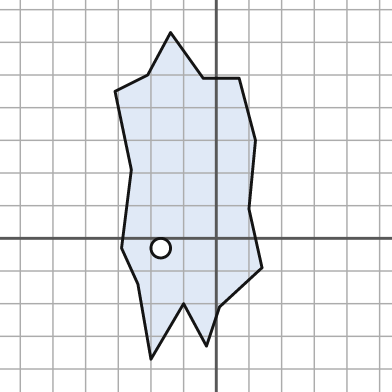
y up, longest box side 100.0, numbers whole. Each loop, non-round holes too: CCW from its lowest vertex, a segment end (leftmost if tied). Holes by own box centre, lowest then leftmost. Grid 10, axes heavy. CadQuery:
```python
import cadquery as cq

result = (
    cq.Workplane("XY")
    .moveTo(-20.0, -37.0)
    .lineTo(-10.0, -20.0)
    .lineTo(-3.0, -33.0)
    .lineTo(1.0, -21.0)
    .lineTo(14.0, -9.0)
    .lineTo(10.0, 9.0)
    .lineTo(12.0, 30.0)
    .lineTo(7.0, 49.0)
    .lineTo(-4.0, 49.0)
    .lineTo(-14.0, 63.0)
    .lineTo(-21.0, 50.0)
    .lineTo(-31.0, 45.0)
    .lineTo(-26.0, 21.0)
    .lineTo(-29.0, -3.0)
    .lineTo(-24.0, -14.0)
    .close()
    .moveTo(-17.0, -3.0)
    .circle(3.0)
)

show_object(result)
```